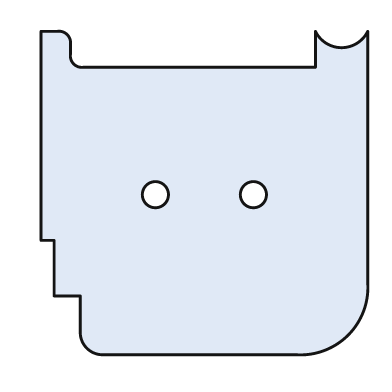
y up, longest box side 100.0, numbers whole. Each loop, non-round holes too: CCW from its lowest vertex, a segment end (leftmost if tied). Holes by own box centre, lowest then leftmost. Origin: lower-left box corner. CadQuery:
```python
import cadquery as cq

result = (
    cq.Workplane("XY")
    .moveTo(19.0, 0.0)
    .lineTo(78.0, 0.0)
    .threePointArc((94.0, 6.0), (100.0, 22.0))
    .lineTo(100.0, 99.0)
    .threePointArc((92.0, 94.0), (84.0, 99.0))
    .lineTo(84.0, 88.0)
    .lineTo(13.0, 88.0)
    .threePointArc((10.0, 89.0), (9.0, 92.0))
    .lineTo(9.0, 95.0)
    .threePointArc((8.0, 98.0), (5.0, 99.0))
    .lineTo(0.0, 99.0)
    .lineTo(0.0, 35.0)
    .lineTo(4.0, 35.0)
    .lineTo(4.0, 18.0)
    .lineTo(12.0, 18.0)
    .lineTo(12.0, 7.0)
    .threePointArc((14.0, 2.0), (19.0, 0.0))
    .close()
    .moveTo(35.0, 49.0)
    .circle(4.0)
    .moveTo(65.0, 49.0)
    .circle(4.0)
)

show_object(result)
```